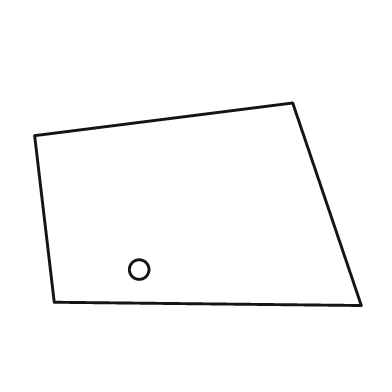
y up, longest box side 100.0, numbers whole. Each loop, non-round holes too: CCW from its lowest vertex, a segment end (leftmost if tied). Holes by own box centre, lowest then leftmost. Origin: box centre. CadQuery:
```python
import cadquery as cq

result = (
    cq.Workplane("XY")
    .moveTo(50.0, -31.0)
    .lineTo(29.0, 31.0)
    .lineTo(-50.0, 21.0)
    .lineTo(-44.0, -30.0)
    .close()
    .moveTo(-18.0, -20.0)
    .circle(3.0)
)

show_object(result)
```